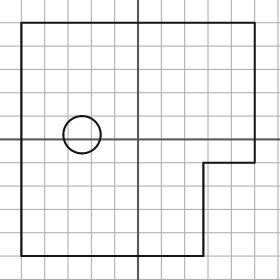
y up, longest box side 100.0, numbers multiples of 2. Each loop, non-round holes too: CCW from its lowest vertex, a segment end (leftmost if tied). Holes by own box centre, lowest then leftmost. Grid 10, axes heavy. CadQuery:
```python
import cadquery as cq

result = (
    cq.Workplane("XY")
    .moveTo(-50.0, -50.0)
    .lineTo(28.0, -50.0)
    .lineTo(28.0, -10.0)
    .lineTo(50.0, -10.0)
    .lineTo(50.0, 50.0)
    .lineTo(-50.0, 50.0)
    .close()
    .moveTo(-24.0, 2.0)
    .circle(8.0)
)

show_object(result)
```